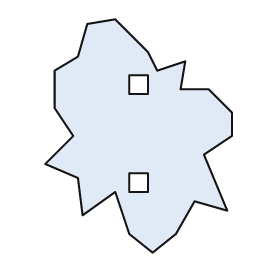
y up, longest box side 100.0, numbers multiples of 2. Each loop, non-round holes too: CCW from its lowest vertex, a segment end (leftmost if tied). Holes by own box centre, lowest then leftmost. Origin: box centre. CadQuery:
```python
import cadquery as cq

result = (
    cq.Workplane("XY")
    .moveTo(6.0, -50.0)
    .lineTo(16.0, -42.0)
    .lineTo(24.0, -28.0)
    .lineTo(38.0, -32.0)
    .lineTo(28.0, -8.0)
    .lineTo(40.0, 0.0)
    .lineTo(40.0, 10.0)
    .lineTo(30.0, 20.0)
    .lineTo(18.0, 20.0)
    .lineTo(20.0, 32.0)
    .lineTo(8.0, 28.0)
    .lineTo(4.0, 36.0)
    .lineTo(-10.0, 50.0)
    .lineTo(-22.0, 48.0)
    .lineTo(-26.0, 34.0)
    .lineTo(-36.0, 28.0)
    .lineTo(-36.0, 12.0)
    .lineTo(-28.0, 0.0)
    .lineTo(-40.0, -12.0)
    .lineTo(-26.0, -18.0)
    .lineTo(-24.0, -34.0)
    .lineTo(-10.0, -24.0)
    .lineTo(-4.0, -42.0)
    .close()
    .moveTo(-4.0, -24.0)
    .lineTo(4.0, -24.0)
    .lineTo(4.0, -16.0)
    .lineTo(-4.0, -16.0)
    .close()
    .moveTo(-4.0, 18.0)
    .lineTo(4.0, 18.0)
    .lineTo(4.0, 26.0)
    .lineTo(-4.0, 26.0)
    .close()
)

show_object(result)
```